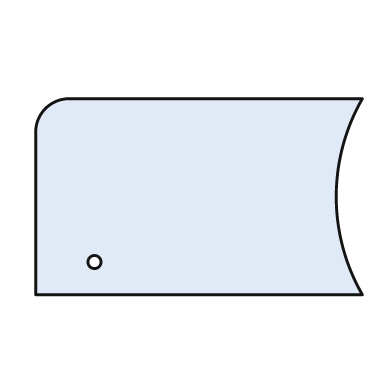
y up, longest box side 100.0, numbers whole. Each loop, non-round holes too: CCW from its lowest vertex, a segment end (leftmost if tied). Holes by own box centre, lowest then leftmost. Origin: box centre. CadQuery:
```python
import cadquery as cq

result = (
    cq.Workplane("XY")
    .moveTo(-50.0, -30.0)
    .lineTo(50.0, -30.0)
    .threePointArc((42.0, 0.0), (50.0, 30.0))
    .lineTo(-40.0, 30.0)
    .threePointArc((-47.0, 27.0), (-50.0, 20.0))
    .close()
    .moveTo(-32.0, -20.0)
    .circle(2.0)
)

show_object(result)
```